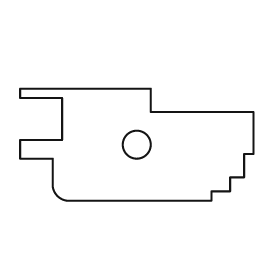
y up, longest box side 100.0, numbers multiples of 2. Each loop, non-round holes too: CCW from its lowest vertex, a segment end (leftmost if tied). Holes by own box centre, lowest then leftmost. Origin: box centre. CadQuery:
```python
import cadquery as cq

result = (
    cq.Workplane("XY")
    .moveTo(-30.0, -24.0)
    .lineTo(32.0, -24.0)
    .lineTo(32.0, -20.0)
    .lineTo(40.0, -20.0)
    .lineTo(40.0, -14.0)
    .lineTo(46.0, -14.0)
    .lineTo(46.0, -4.0)
    .lineTo(50.0, -4.0)
    .lineTo(50.0, 14.0)
    .lineTo(6.0, 14.0)
    .lineTo(6.0, 24.0)
    .lineTo(-50.0, 24.0)
    .lineTo(-50.0, 20.0)
    .lineTo(-32.0, 20.0)
    .lineTo(-32.0, 2.0)
    .lineTo(-50.0, 2.0)
    .lineTo(-50.0, -6.0)
    .lineTo(-36.0, -6.0)
    .lineTo(-36.0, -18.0)
    .threePointArc((-34.0, -22.0), (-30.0, -24.0))
    .close()
    .moveTo(0.0, 0.0)
    .circle(6.0)
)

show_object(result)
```